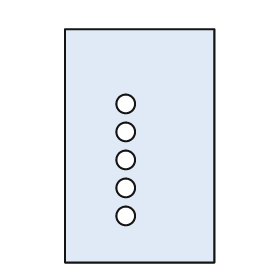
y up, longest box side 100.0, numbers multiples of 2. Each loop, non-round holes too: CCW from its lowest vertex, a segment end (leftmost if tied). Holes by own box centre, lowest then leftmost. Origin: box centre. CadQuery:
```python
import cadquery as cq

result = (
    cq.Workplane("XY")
    .moveTo(-32.0, -50.0)
    .lineTo(32.0, -50.0)
    .lineTo(32.0, 50.0)
    .lineTo(-32.0, 50.0)
    .close()
    .moveTo(-6.0, -30.0)
    .circle(4.0)
    .moveTo(-6.0, -18.0)
    .circle(4.0)
    .moveTo(-6.0, -6.0)
    .circle(4.0)
    .moveTo(-6.0, 6.0)
    .circle(4.0)
    .moveTo(-6.0, 18.0)
    .circle(4.0)
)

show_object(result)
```